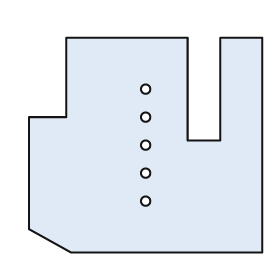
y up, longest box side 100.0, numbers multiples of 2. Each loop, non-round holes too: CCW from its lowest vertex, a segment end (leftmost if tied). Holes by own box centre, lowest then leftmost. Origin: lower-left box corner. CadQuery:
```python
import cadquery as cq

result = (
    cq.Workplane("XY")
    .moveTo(18.0, 0.0)
    .lineTo(100.0, 0.0)
    .lineTo(100.0, 92.0)
    .lineTo(82.0, 92.0)
    .lineTo(82.0, 48.0)
    .lineTo(68.0, 48.0)
    .lineTo(68.0, 92.0)
    .lineTo(16.0, 92.0)
    .lineTo(16.0, 58.0)
    .lineTo(0.0, 58.0)
    .lineTo(0.0, 10.0)
    .close()
    .moveTo(50.0, 22.0)
    .circle(2.0)
    .moveTo(50.0, 34.0)
    .circle(2.0)
    .moveTo(50.0, 46.0)
    .circle(2.0)
    .moveTo(50.0, 58.0)
    .circle(2.0)
    .moveTo(50.0, 70.0)
    .circle(2.0)
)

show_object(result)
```